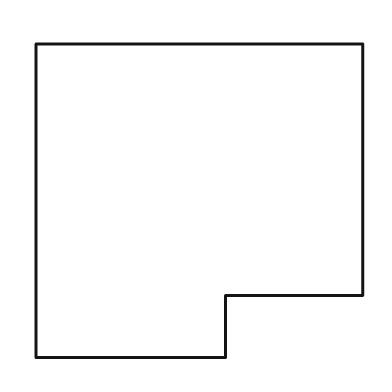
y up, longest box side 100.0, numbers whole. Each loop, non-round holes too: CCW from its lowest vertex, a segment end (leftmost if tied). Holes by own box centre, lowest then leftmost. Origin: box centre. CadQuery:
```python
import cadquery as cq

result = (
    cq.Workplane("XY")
    .moveTo(-50.0, -48.0)
    .lineTo(8.0, -48.0)
    .lineTo(8.0, -29.0)
    .lineTo(50.0, -29.0)
    .lineTo(50.0, 48.0)
    .lineTo(-50.0, 48.0)
    .close()
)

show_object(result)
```